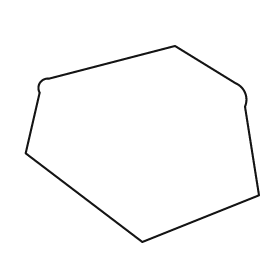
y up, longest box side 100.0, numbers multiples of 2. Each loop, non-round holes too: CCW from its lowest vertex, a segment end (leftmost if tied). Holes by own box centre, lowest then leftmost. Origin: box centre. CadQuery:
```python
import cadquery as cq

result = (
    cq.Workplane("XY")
    .moveTo(0.0, -42.0)
    .lineTo(50.0, -22.0)
    .lineTo(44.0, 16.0)
    .threePointArc((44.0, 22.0), (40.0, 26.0))
    .lineTo(14.0, 42.0)
    .lineTo(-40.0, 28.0)
    .threePointArc((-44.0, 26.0), (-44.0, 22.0))
    .lineTo(-50.0, -4.0)
    .close()
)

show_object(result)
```